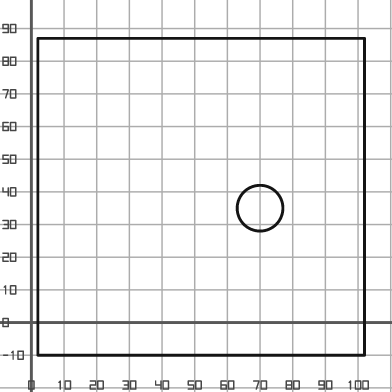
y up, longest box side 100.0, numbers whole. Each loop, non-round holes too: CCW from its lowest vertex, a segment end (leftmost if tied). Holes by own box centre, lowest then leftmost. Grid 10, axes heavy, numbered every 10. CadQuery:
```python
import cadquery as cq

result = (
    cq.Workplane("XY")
    .moveTo(2.0, -10.0)
    .lineTo(102.0, -10.0)
    .lineTo(102.0, 87.0)
    .lineTo(2.0, 87.0)
    .close()
    .moveTo(70.0, 35.0)
    .circle(7.0)
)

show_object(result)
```